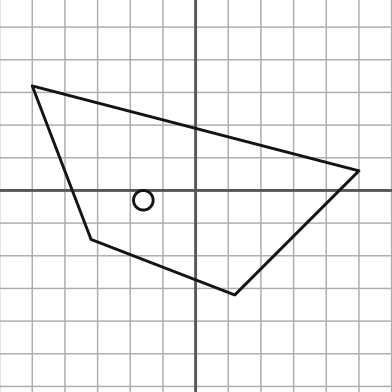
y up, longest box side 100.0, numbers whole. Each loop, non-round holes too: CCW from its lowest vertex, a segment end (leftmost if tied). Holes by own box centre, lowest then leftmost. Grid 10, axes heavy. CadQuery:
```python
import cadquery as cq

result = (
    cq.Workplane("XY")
    .moveTo(12.0, -32.0)
    .lineTo(50.0, 6.0)
    .lineTo(-50.0, 32.0)
    .lineTo(-32.0, -15.0)
    .close()
    .moveTo(-16.0, -3.0)
    .circle(3.0)
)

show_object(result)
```